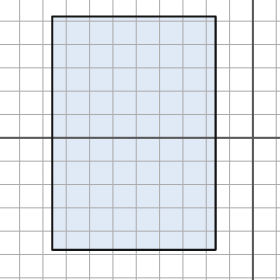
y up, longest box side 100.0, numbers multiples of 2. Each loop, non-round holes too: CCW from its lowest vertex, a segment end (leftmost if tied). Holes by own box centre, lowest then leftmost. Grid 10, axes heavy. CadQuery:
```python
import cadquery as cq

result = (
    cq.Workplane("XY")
    .moveTo(-86.0, -48.0)
    .lineTo(-16.0, -48.0)
    .lineTo(-16.0, 52.0)
    .lineTo(-86.0, 52.0)
    .close()
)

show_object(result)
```